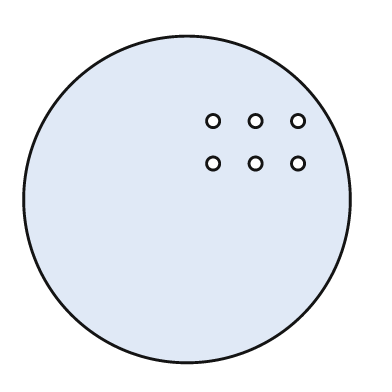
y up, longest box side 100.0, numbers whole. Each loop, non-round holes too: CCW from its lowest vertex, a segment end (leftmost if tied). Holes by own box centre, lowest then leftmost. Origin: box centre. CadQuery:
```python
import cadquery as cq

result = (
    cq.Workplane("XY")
    .moveTo(0.0, 0.0)
    .circle(50.0)
    .moveTo(8.0, 11.0)
    .circle(2.0)
    .moveTo(21.0, 11.0)
    .circle(2.0)
    .moveTo(34.0, 11.0)
    .circle(2.0)
    .moveTo(8.0, 24.0)
    .circle(2.0)
    .moveTo(21.0, 24.0)
    .circle(2.0)
    .moveTo(34.0, 24.0)
    .circle(2.0)
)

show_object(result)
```